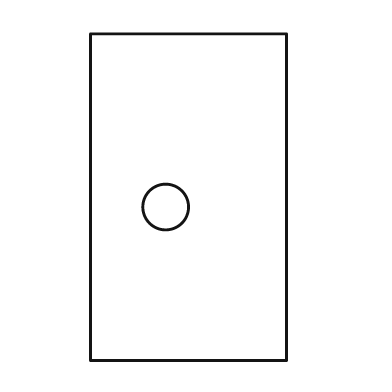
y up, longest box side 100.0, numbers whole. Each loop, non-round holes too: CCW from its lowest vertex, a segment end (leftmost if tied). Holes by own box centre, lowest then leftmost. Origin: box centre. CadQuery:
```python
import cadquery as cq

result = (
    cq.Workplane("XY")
    .moveTo(-30.0, -50.0)
    .lineTo(30.0, -50.0)
    .lineTo(30.0, 50.0)
    .lineTo(-30.0, 50.0)
    .close()
    .moveTo(-7.0, -3.0)
    .circle(7.0)
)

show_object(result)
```